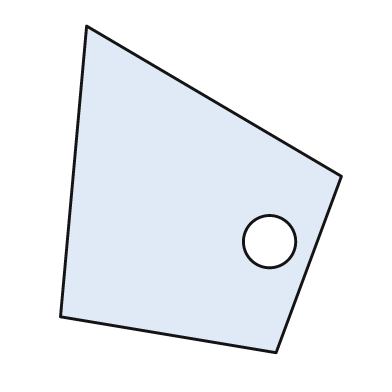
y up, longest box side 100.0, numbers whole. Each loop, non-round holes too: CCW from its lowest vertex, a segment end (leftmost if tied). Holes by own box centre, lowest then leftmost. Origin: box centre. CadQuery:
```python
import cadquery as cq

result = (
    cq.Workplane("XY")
    .moveTo(23.0, -50.0)
    .lineTo(43.0, 4.0)
    .lineTo(-35.0, 50.0)
    .lineTo(-43.0, -39.0)
    .close()
    .moveTo(21.0, -16.0)
    .circle(8.0)
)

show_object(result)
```